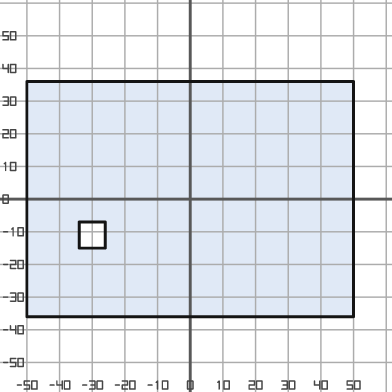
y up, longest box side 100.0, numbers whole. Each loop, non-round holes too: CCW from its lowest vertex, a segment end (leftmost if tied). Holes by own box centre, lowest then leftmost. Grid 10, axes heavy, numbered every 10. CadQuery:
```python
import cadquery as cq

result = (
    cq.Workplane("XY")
    .moveTo(-50.0, -36.0)
    .lineTo(50.0, -36.0)
    .lineTo(50.0, 36.0)
    .lineTo(-50.0, 36.0)
    .close()
    .moveTo(-34.0, -15.0)
    .lineTo(-26.0, -15.0)
    .lineTo(-26.0, -7.0)
    .lineTo(-34.0, -7.0)
    .close()
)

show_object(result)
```